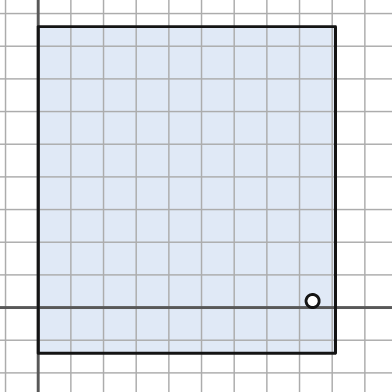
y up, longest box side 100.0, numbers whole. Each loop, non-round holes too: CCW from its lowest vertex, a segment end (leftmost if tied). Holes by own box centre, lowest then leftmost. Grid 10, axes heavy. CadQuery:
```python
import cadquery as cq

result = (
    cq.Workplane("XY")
    .moveTo(0.0, -14.0)
    .lineTo(91.0, -14.0)
    .lineTo(91.0, 86.0)
    .lineTo(0.0, 86.0)
    .close()
    .moveTo(84.0, 2.0)
    .circle(2.0)
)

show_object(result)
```